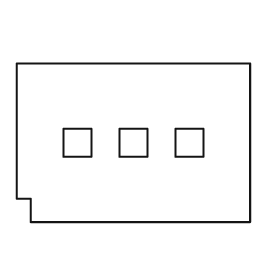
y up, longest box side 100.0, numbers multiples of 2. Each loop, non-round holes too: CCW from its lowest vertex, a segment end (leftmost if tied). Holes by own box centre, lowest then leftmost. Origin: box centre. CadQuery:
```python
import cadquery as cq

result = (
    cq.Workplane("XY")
    .moveTo(-44.0, -34.0)
    .lineTo(50.0, -34.0)
    .lineTo(50.0, 34.0)
    .lineTo(-50.0, 34.0)
    .lineTo(-50.0, -24.0)
    .lineTo(-44.0, -24.0)
    .close()
    .moveTo(-30.0, -6.0)
    .lineTo(-18.0, -6.0)
    .lineTo(-18.0, 6.0)
    .lineTo(-30.0, 6.0)
    .close()
    .moveTo(-6.0, -6.0)
    .lineTo(6.0, -6.0)
    .lineTo(6.0, 6.0)
    .lineTo(-6.0, 6.0)
    .close()
    .moveTo(18.0, -6.0)
    .lineTo(30.0, -6.0)
    .lineTo(30.0, 6.0)
    .lineTo(18.0, 6.0)
    .close()
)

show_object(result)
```